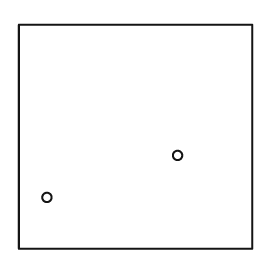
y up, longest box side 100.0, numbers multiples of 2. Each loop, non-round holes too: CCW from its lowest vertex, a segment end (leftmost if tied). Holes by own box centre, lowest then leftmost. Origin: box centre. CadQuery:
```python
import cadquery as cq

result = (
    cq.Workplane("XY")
    .moveTo(-50.0, -48.0)
    .lineTo(50.0, -48.0)
    .lineTo(50.0, 48.0)
    .lineTo(-50.0, 48.0)
    .close()
    .moveTo(-38.0, -26.0)
    .circle(2.0)
    .moveTo(18.0, -8.0)
    .circle(2.0)
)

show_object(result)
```